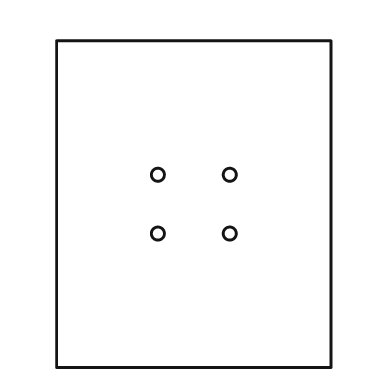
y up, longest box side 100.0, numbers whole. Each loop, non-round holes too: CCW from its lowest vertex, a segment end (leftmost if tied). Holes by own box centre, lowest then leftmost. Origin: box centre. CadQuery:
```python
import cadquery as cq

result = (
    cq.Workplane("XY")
    .moveTo(-42.0, -50.0)
    .lineTo(42.0, -50.0)
    .lineTo(42.0, 50.0)
    .lineTo(-42.0, 50.0)
    .close()
    .moveTo(-11.0, -9.0)
    .circle(2.0)
    .moveTo(11.0, -9.0)
    .circle(2.0)
    .moveTo(-11.0, 9.0)
    .circle(2.0)
    .moveTo(11.0, 9.0)
    .circle(2.0)
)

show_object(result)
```